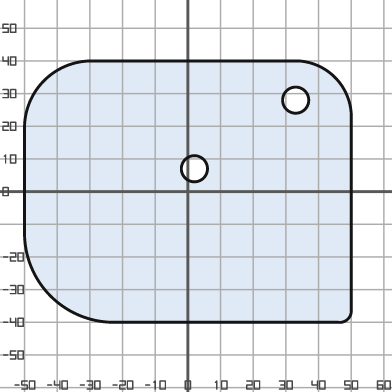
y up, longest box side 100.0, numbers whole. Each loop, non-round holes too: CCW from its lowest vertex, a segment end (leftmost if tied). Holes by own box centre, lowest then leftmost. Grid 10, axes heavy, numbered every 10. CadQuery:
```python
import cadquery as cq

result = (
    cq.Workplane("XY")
    .moveTo(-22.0, -40.0)
    .lineTo(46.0, -40.0)
    .threePointArc((49.0, -39.0), (50.0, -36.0))
    .lineTo(50.0, 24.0)
    .threePointArc((45.0, 35.0), (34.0, 40.0))
    .lineTo(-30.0, 40.0)
    .threePointArc((-44.0, 34.0), (-50.0, 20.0))
    .lineTo(-50.0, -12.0)
    .threePointArc((-42.0, -32.0), (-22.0, -40.0))
    .close()
    .moveTo(2.0, 7.0)
    .circle(4.0)
    .moveTo(33.0, 28.0)
    .circle(4.0)
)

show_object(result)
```